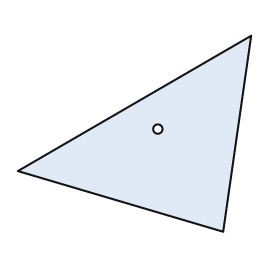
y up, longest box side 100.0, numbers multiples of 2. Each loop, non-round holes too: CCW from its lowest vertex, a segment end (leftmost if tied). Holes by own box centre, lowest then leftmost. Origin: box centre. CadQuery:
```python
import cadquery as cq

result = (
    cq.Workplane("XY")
    .moveTo(38.0, -42.0)
    .lineTo(50.0, 42.0)
    .lineTo(-50.0, -16.0)
    .close()
    .moveTo(10.0, 2.0)
    .circle(2.0)
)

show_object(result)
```